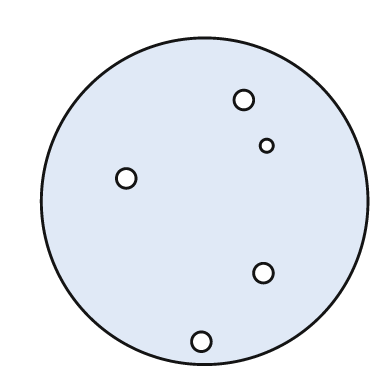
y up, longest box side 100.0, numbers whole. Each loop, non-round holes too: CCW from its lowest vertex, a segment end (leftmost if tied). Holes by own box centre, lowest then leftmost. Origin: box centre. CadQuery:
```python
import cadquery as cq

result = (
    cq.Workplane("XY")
    .moveTo(0.0, 0.0)
    .circle(50.0)
    .moveTo(-1.0, -43.0)
    .circle(3.0)
    .moveTo(18.0, -22.0)
    .circle(3.0)
    .moveTo(-24.0, 7.0)
    .circle(3.0)
    .moveTo(19.0, 17.0)
    .circle(2.0)
    .moveTo(12.0, 31.0)
    .circle(3.0)
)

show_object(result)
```